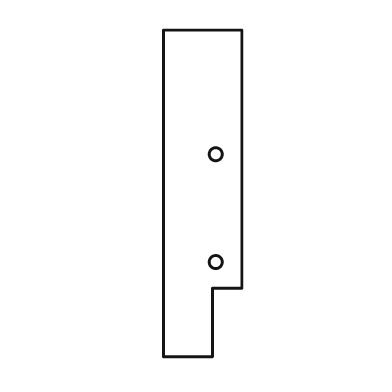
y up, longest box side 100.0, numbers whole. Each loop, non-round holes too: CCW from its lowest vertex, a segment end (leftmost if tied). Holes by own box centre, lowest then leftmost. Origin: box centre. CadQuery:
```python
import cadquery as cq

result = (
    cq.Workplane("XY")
    .moveTo(-12.0, -50.0)
    .lineTo(3.0, -50.0)
    .lineTo(3.0, -29.0)
    .lineTo(12.0, -29.0)
    .lineTo(12.0, 50.0)
    .lineTo(-12.0, 50.0)
    .close()
    .moveTo(4.0, -21.0)
    .circle(2.0)
    .moveTo(4.0, 12.0)
    .circle(2.0)
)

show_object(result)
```